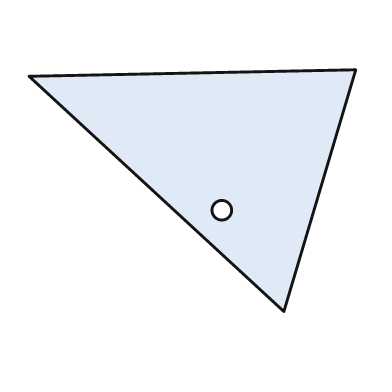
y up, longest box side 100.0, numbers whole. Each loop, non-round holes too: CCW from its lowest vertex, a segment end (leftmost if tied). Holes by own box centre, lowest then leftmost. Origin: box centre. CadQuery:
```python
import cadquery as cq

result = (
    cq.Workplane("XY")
    .moveTo(28.0, -37.0)
    .lineTo(50.0, 37.0)
    .lineTo(-50.0, 35.0)
    .close()
    .moveTo(9.0, -6.0)
    .circle(3.0)
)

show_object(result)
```